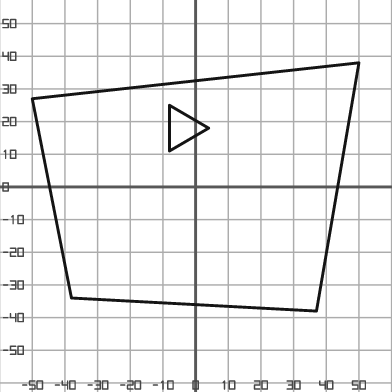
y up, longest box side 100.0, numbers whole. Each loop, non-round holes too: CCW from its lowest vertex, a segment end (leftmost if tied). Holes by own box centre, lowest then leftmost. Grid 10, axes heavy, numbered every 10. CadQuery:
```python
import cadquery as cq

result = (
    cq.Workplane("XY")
    .moveTo(37.0, -38.0)
    .lineTo(50.0, 38.0)
    .lineTo(-50.0, 27.0)
    .lineTo(-38.0, -34.0)
    .close()
    .moveTo(-8.0, 11.0)
    .lineTo(4.0, 18.0)
    .lineTo(-8.0, 25.0)
    .close()
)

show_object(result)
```